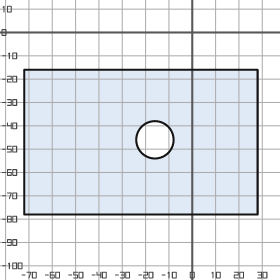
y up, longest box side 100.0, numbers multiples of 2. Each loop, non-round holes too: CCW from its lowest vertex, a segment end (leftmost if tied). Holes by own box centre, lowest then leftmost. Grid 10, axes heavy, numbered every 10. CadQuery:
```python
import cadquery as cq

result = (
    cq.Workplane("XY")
    .moveTo(-72.0, -78.0)
    .lineTo(28.0, -78.0)
    .lineTo(28.0, -16.0)
    .lineTo(-72.0, -16.0)
    .close()
    .moveTo(-16.0, -46.0)
    .circle(8.0)
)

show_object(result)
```